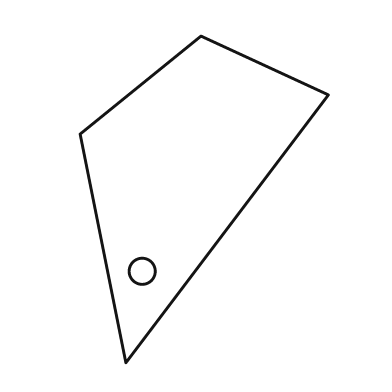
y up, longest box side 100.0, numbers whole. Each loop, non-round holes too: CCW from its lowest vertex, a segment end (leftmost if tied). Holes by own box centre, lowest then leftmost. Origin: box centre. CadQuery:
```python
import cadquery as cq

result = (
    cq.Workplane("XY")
    .moveTo(-24.0, -50.0)
    .lineTo(38.0, 32.0)
    .lineTo(-1.0, 50.0)
    .lineTo(-38.0, 20.0)
    .close()
    .moveTo(-19.0, -22.0)
    .circle(4.0)
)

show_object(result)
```